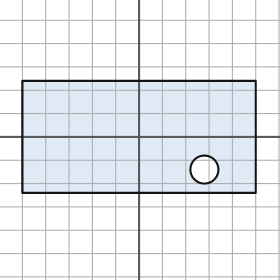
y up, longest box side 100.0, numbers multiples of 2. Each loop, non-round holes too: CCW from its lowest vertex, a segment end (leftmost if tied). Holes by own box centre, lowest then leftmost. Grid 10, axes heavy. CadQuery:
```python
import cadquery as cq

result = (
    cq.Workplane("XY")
    .moveTo(-50.0, -24.0)
    .lineTo(50.0, -24.0)
    .lineTo(50.0, 24.0)
    .lineTo(-50.0, 24.0)
    .close()
    .moveTo(28.0, -14.0)
    .circle(6.0)
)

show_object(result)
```